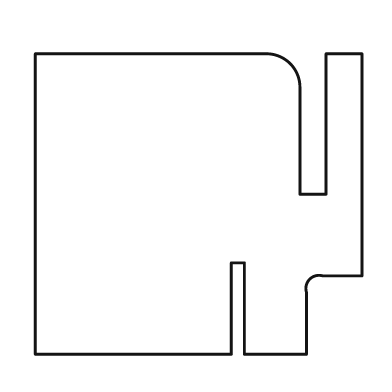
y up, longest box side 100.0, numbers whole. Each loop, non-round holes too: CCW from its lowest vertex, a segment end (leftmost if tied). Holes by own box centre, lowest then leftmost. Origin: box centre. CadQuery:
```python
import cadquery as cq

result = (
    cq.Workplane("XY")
    .moveTo(-50.0, -46.0)
    .lineTo(10.0, -46.0)
    .lineTo(10.0, -18.0)
    .lineTo(14.0, -18.0)
    .lineTo(14.0, -46.0)
    .lineTo(33.0, -46.0)
    .lineTo(33.0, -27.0)
    .threePointArc((34.0, -23.0), (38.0, -22.0))
    .lineTo(50.0, -22.0)
    .lineTo(50.0, 46.0)
    .lineTo(39.0, 46.0)
    .lineTo(39.0, 3.0)
    .lineTo(31.0, 3.0)
    .lineTo(31.0, 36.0)
    .threePointArc((28.0, 43.0), (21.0, 46.0))
    .lineTo(-50.0, 46.0)
    .close()
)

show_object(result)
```